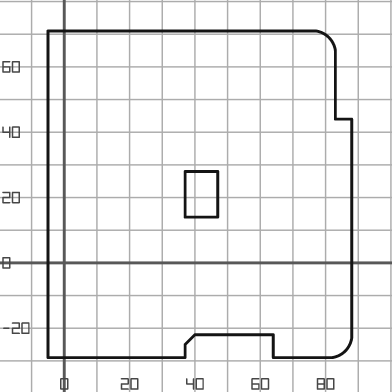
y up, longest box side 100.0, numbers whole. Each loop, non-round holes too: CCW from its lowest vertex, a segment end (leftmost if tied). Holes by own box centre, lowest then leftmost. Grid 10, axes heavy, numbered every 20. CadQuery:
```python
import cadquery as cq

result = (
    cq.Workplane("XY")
    .moveTo(-5.0, -29.0)
    .lineTo(37.0, -29.0)
    .lineTo(37.0, -25.0)
    .lineTo(40.0, -22.0)
    .lineTo(64.0, -22.0)
    .lineTo(64.0, -29.0)
    .lineTo(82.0, -29.0)
    .threePointArc((86.0, -27.0), (88.0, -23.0))
    .lineTo(88.0, 44.0)
    .lineTo(83.0, 44.0)
    .lineTo(83.0, 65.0)
    .threePointArc((81.0, 69.0), (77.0, 71.0))
    .lineTo(-5.0, 71.0)
    .close()
    .moveTo(37.0, 14.0)
    .lineTo(47.0, 14.0)
    .lineTo(47.0, 28.0)
    .lineTo(37.0, 28.0)
    .close()
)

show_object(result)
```